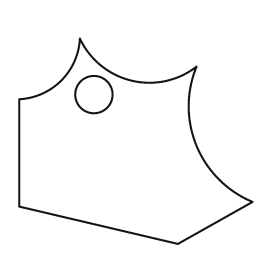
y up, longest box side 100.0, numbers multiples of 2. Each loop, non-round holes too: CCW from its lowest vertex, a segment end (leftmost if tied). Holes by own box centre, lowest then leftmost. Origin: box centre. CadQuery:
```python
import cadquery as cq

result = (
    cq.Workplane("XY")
    .moveTo(18.0, -44.0)
    .lineTo(50.0, -26.0)
    .threePointArc((26.0, -2.0), (26.0, 32.0))
    .threePointArc((-2.0, 26.0), (-24.0, 44.0))
    .threePointArc((-32.0, 26.0), (-50.0, 18.0))
    .lineTo(-50.0, -28.0)
    .close()
    .moveTo(-18.0, 20.0)
    .circle(8.0)
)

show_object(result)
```